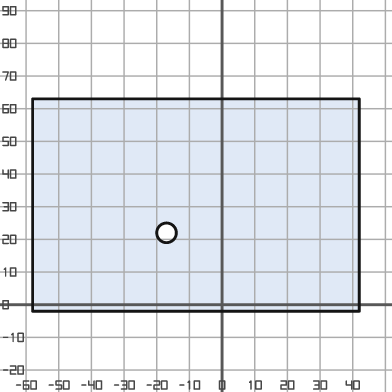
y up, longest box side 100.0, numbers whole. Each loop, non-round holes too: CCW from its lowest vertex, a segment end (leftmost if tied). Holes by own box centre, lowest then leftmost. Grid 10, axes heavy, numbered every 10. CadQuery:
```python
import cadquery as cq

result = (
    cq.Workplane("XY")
    .moveTo(-58.0, -2.0)
    .lineTo(42.0, -2.0)
    .lineTo(42.0, 63.0)
    .lineTo(-58.0, 63.0)
    .close()
    .moveTo(-17.0, 22.0)
    .circle(3.0)
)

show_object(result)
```